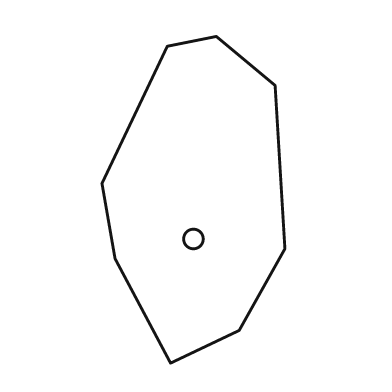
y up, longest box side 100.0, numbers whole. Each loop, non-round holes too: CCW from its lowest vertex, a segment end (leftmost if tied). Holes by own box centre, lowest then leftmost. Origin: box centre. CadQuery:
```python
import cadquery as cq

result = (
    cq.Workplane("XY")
    .moveTo(-7.0, -50.0)
    .lineTo(14.0, -40.0)
    .lineTo(28.0, -15.0)
    .lineTo(25.0, 35.0)
    .lineTo(7.0, 50.0)
    .lineTo(-8.0, 47.0)
    .lineTo(-28.0, 5.0)
    .lineTo(-24.0, -18.0)
    .close()
    .moveTo(0.0, -12.0)
    .circle(3.0)
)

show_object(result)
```